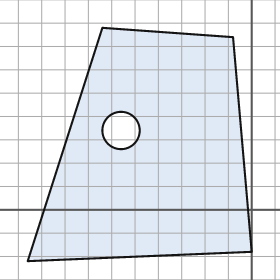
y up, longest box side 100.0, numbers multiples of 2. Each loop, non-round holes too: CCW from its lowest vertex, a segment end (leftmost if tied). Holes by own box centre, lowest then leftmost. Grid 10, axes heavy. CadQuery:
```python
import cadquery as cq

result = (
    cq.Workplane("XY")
    .moveTo(-96.0, -22.0)
    .lineTo(0.0, -18.0)
    .lineTo(-8.0, 74.0)
    .lineTo(-64.0, 78.0)
    .close()
    .moveTo(-56.0, 34.0)
    .circle(8.0)
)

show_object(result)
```